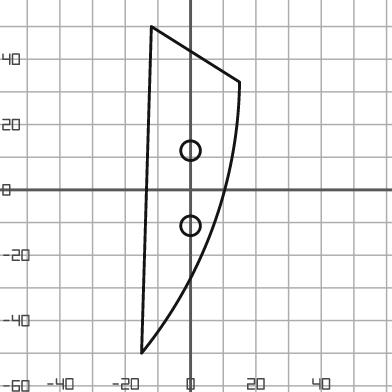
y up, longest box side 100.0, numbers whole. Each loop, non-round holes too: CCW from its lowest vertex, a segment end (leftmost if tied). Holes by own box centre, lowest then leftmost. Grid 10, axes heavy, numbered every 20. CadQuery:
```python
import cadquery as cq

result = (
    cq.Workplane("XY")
    .moveTo(-15.0, -50.0)
    .threePointArc((7.0, -11.0), (15.0, 33.0))
    .lineTo(-12.0, 50.0)
    .close()
    .moveTo(0.0, -11.0)
    .circle(3.0)
    .moveTo(0.0, 12.0)
    .circle(3.0)
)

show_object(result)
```